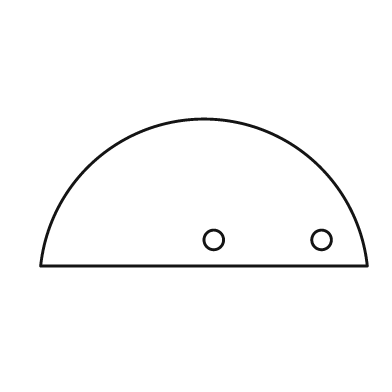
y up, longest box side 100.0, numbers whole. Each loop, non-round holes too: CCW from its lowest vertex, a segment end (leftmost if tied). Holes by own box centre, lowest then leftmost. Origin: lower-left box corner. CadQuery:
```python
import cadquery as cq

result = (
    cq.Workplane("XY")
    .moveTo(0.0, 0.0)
    .lineTo(100.0, 0.0)
    .threePointArc((50.0, 45.0), (0.0, 0.0))
    .close()
    .moveTo(53.0, 8.0)
    .circle(3.0)
    .moveTo(86.0, 8.0)
    .circle(3.0)
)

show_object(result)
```